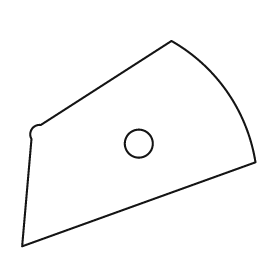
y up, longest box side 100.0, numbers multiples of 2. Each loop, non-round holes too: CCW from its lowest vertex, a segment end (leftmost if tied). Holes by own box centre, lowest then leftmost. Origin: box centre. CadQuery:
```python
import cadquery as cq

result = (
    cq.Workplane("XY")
    .moveTo(-50.0, -44.0)
    .lineTo(50.0, -8.0)
    .threePointArc((38.0, 22.0), (14.0, 44.0))
    .lineTo(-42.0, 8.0)
    .threePointArc((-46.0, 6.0), (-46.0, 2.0))
    .close()
    .moveTo(0.0, 0.0)
    .circle(6.0)
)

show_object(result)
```